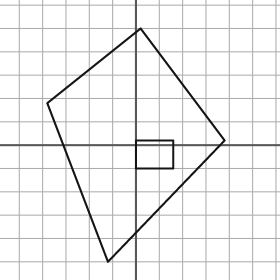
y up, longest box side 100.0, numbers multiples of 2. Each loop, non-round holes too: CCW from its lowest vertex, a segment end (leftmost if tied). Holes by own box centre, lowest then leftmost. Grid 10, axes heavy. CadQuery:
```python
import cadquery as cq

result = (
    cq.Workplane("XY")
    .moveTo(-12.0, -50.0)
    .lineTo(38.0, 2.0)
    .lineTo(2.0, 50.0)
    .lineTo(-38.0, 18.0)
    .close()
    .moveTo(0.0, -10.0)
    .lineTo(16.0, -10.0)
    .lineTo(16.0, 2.0)
    .lineTo(0.0, 2.0)
    .close()
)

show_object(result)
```